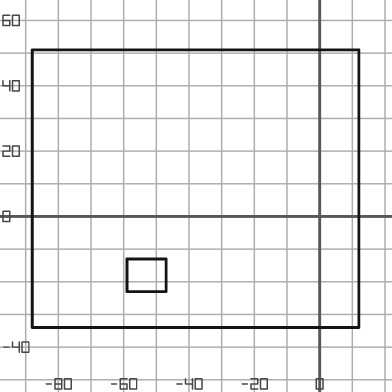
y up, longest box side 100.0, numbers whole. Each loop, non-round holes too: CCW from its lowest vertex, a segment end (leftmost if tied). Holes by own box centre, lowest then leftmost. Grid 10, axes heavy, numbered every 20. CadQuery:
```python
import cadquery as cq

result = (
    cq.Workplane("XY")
    .moveTo(-88.0, -34.0)
    .lineTo(12.0, -34.0)
    .lineTo(12.0, 51.0)
    .lineTo(-88.0, 51.0)
    .close()
    .moveTo(-59.0, -23.0)
    .lineTo(-47.0, -23.0)
    .lineTo(-47.0, -13.0)
    .lineTo(-59.0, -13.0)
    .close()
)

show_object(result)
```